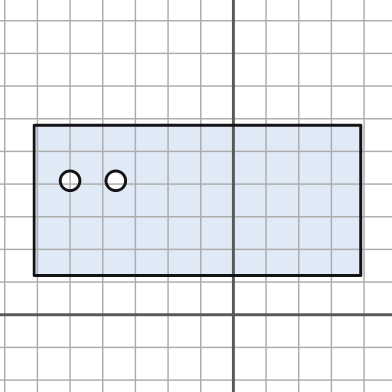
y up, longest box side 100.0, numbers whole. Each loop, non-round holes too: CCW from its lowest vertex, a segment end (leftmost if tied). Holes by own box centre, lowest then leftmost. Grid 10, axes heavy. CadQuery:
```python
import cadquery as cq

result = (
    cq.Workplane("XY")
    .moveTo(-61.0, 12.0)
    .lineTo(39.0, 12.0)
    .lineTo(39.0, 58.0)
    .lineTo(-61.0, 58.0)
    .close()
    .moveTo(-50.0, 41.0)
    .circle(3.0)
    .moveTo(-36.0, 41.0)
    .circle(3.0)
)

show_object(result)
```